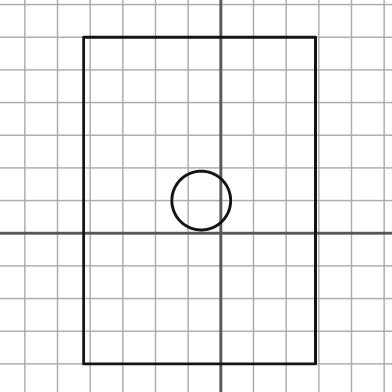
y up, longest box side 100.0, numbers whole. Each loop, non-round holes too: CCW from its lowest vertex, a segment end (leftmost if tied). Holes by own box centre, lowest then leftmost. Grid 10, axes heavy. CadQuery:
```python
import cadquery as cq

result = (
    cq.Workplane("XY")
    .moveTo(-42.0, -40.0)
    .lineTo(29.0, -40.0)
    .lineTo(29.0, 60.0)
    .lineTo(-42.0, 60.0)
    .close()
    .moveTo(-6.0, 10.0)
    .circle(9.0)
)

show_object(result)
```